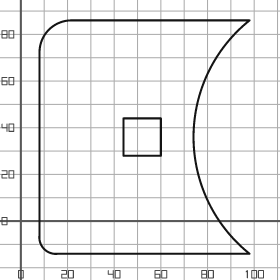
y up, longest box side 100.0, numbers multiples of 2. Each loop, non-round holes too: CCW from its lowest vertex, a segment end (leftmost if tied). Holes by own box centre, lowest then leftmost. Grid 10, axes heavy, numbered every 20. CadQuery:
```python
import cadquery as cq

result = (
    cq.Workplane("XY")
    .moveTo(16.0, -14.0)
    .lineTo(98.0, -14.0)
    .threePointArc((74.0, 36.0), (98.0, 86.0))
    .lineTo(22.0, 86.0)
    .threePointArc((12.0, 82.0), (8.0, 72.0))
    .lineTo(8.0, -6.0)
    .threePointArc((10.0, -12.0), (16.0, -14.0))
    .close()
    .moveTo(44.0, 28.0)
    .lineTo(60.0, 28.0)
    .lineTo(60.0, 44.0)
    .lineTo(44.0, 44.0)
    .close()
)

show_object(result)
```